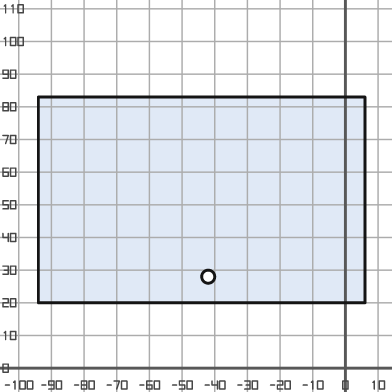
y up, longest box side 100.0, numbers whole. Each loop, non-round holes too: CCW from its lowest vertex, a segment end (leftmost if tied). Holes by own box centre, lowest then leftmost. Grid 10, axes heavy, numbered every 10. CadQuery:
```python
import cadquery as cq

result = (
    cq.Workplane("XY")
    .moveTo(-94.0, 20.0)
    .lineTo(6.0, 20.0)
    .lineTo(6.0, 83.0)
    .lineTo(-94.0, 83.0)
    .close()
    .moveTo(-42.0, 28.0)
    .circle(2.0)
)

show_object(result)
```